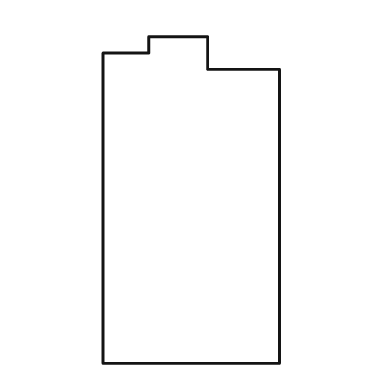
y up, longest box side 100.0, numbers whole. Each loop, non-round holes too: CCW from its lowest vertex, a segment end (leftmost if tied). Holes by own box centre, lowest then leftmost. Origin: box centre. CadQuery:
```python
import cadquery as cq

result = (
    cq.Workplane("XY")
    .moveTo(-27.0, -50.0)
    .lineTo(27.0, -50.0)
    .lineTo(27.0, 40.0)
    .lineTo(5.0, 40.0)
    .lineTo(5.0, 50.0)
    .lineTo(-13.0, 50.0)
    .lineTo(-13.0, 45.0)
    .lineTo(-27.0, 45.0)
    .close()
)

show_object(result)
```